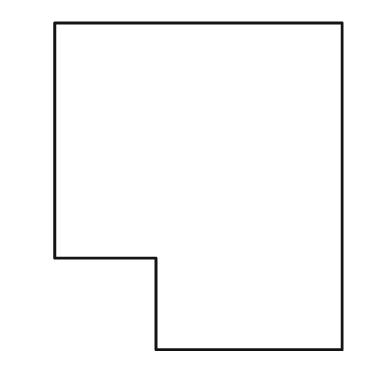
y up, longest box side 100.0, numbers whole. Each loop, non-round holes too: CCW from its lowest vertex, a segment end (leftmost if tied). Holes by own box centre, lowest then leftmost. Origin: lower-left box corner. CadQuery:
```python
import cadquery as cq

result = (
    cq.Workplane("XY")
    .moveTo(31.0, 0.0)
    .lineTo(88.0, 0.0)
    .lineTo(88.0, 100.0)
    .lineTo(0.0, 100.0)
    .lineTo(0.0, 28.0)
    .lineTo(31.0, 28.0)
    .close()
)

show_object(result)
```